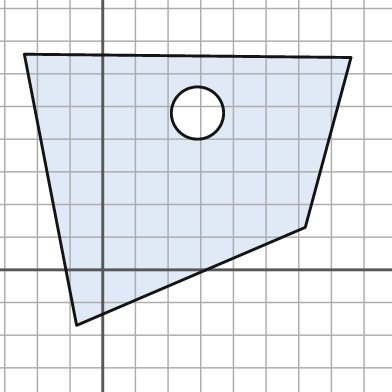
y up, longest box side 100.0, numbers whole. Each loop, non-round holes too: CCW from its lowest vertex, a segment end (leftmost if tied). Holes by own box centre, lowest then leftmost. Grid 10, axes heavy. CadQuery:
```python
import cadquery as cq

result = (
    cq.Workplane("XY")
    .moveTo(-8.0, -17.0)
    .lineTo(62.0, 13.0)
    .lineTo(76.0, 65.0)
    .lineTo(-24.0, 66.0)
    .close()
    .moveTo(29.0, 48.0)
    .circle(8.0)
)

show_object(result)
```